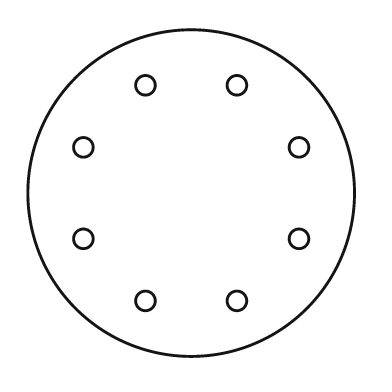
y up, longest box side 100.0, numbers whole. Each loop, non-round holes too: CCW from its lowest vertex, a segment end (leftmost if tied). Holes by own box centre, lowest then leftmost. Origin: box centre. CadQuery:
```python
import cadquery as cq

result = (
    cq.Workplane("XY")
    .moveTo(0.0, 0.0)
    .circle(50.0)
    .moveTo(-14.0, -33.0)
    .circle(3.0)
    .moveTo(14.0, -33.0)
    .circle(3.0)
    .moveTo(-33.0, -14.0)
    .circle(3.0)
    .moveTo(33.0, -14.0)
    .circle(3.0)
    .moveTo(-33.0, 14.0)
    .circle(3.0)
    .moveTo(33.0, 14.0)
    .circle(3.0)
    .moveTo(-14.0, 33.0)
    .circle(3.0)
    .moveTo(14.0, 33.0)
    .circle(3.0)
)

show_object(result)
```